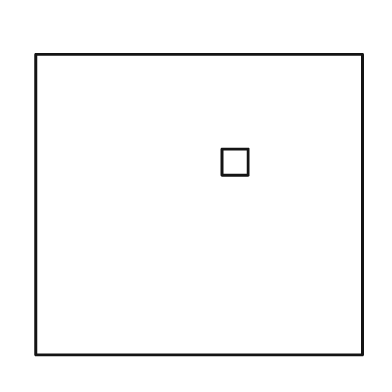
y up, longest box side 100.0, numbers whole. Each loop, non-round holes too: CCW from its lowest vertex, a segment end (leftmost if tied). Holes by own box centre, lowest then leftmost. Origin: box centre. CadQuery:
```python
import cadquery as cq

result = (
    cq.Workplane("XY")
    .moveTo(-50.0, -46.0)
    .lineTo(50.0, -46.0)
    .lineTo(50.0, 46.0)
    .lineTo(-50.0, 46.0)
    .close()
    .moveTo(7.0, 9.0)
    .lineTo(15.0, 9.0)
    .lineTo(15.0, 17.0)
    .lineTo(7.0, 17.0)
    .close()
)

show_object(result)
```